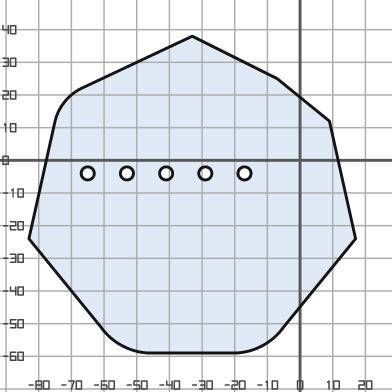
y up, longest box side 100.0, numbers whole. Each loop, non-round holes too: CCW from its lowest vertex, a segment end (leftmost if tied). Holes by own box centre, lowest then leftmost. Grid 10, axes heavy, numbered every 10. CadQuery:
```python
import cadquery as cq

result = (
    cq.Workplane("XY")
    .moveTo(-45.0, -59.0)
    .lineTo(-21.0, -59.0)
    .threePointArc((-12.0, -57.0), (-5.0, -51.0))
    .lineTo(17.0, -24.0)
    .lineTo(9.0, 12.0)
    .lineTo(-7.0, 25.0)
    .lineTo(-33.0, 38.0)
    .lineTo(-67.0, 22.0)
    .threePointArc((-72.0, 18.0), (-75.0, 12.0))
    .lineTo(-83.0, -24.0)
    .lineTo(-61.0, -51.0)
    .threePointArc((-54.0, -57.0), (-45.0, -59.0))
    .close()
    .moveTo(-65.0, -4.0)
    .circle(2.0)
    .moveTo(-53.0, -4.0)
    .circle(2.0)
    .moveTo(-41.0, -4.0)
    .circle(2.0)
    .moveTo(-29.0, -4.0)
    .circle(2.0)
    .moveTo(-17.0, -4.0)
    .circle(2.0)
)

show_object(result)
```